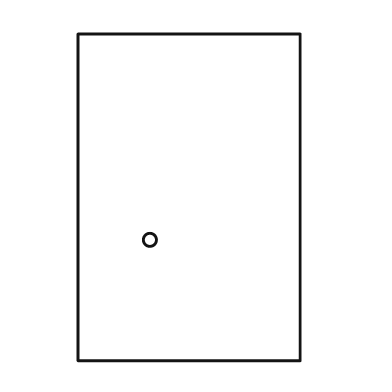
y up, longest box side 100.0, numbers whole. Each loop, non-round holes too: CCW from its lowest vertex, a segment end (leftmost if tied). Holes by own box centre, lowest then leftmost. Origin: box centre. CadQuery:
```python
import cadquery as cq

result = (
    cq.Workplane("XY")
    .moveTo(-34.0, -50.0)
    .lineTo(34.0, -50.0)
    .lineTo(34.0, 50.0)
    .lineTo(-34.0, 50.0)
    .close()
    .moveTo(-12.0, -13.0)
    .circle(2.0)
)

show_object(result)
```